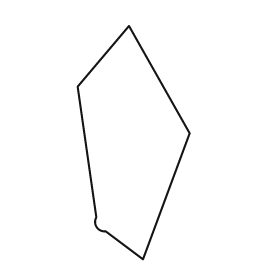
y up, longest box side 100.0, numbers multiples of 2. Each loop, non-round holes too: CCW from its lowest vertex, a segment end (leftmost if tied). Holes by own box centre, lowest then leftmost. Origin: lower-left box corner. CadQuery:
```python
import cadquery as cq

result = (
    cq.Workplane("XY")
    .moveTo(28.0, 0.0)
    .lineTo(48.0, 54.0)
    .lineTo(22.0, 100.0)
    .lineTo(0.0, 74.0)
    .lineTo(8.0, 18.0)
    .threePointArc((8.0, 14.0), (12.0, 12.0))
    .close()
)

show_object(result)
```